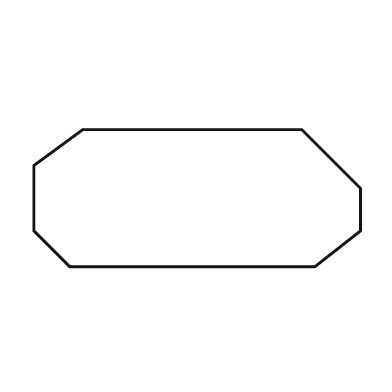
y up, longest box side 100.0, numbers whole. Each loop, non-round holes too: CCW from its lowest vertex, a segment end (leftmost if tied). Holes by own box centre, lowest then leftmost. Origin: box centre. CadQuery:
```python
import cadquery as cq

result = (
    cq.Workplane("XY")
    .moveTo(-39.0, -21.0)
    .lineTo(36.0, -21.0)
    .lineTo(50.0, -10.0)
    .lineTo(50.0, 3.0)
    .lineTo(32.0, 21.0)
    .lineTo(-35.0, 21.0)
    .lineTo(-50.0, 10.0)
    .lineTo(-50.0, -10.0)
    .close()
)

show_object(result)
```